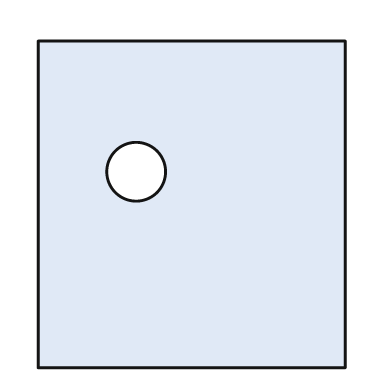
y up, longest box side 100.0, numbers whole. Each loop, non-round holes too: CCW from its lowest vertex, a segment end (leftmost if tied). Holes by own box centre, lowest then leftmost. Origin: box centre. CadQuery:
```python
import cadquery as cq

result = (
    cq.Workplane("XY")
    .moveTo(-47.0, -50.0)
    .lineTo(47.0, -50.0)
    .lineTo(47.0, 50.0)
    .lineTo(-47.0, 50.0)
    .close()
    .moveTo(-17.0, 10.0)
    .circle(9.0)
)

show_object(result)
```